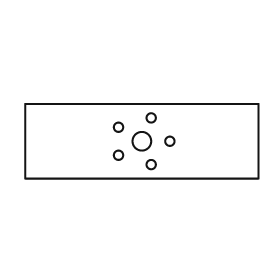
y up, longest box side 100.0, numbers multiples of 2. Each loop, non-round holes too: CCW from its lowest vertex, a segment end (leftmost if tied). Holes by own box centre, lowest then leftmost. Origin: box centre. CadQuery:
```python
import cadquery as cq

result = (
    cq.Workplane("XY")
    .moveTo(-50.0, -16.0)
    .lineTo(50.0, -16.0)
    .lineTo(50.0, 16.0)
    .lineTo(-50.0, 16.0)
    .close()
    .moveTo(4.0, -10.0)
    .circle(2.0)
    .moveTo(-10.0, -6.0)
    .circle(2.0)
    .moveTo(0.0, 0.0)
    .circle(4.0)
    .moveTo(12.0, 0.0)
    .circle(2.0)
    .moveTo(-10.0, 6.0)
    .circle(2.0)
    .moveTo(4.0, 10.0)
    .circle(2.0)
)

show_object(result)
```